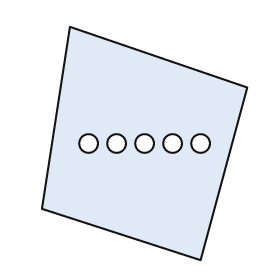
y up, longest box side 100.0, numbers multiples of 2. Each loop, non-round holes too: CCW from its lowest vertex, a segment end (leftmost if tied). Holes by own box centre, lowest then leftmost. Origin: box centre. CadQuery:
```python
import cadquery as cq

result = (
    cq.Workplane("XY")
    .moveTo(24.0, -50.0)
    .lineTo(44.0, 24.0)
    .lineTo(-32.0, 50.0)
    .lineTo(-44.0, -28.0)
    .close()
    .moveTo(-24.0, 0.0)
    .circle(4.0)
    .moveTo(-12.0, 0.0)
    .circle(4.0)
    .moveTo(0.0, 0.0)
    .circle(4.0)
    .moveTo(12.0, 0.0)
    .circle(4.0)
    .moveTo(24.0, 0.0)
    .circle(4.0)
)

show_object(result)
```